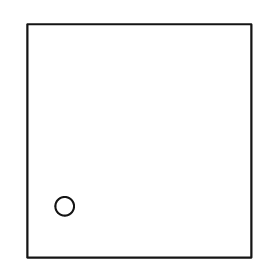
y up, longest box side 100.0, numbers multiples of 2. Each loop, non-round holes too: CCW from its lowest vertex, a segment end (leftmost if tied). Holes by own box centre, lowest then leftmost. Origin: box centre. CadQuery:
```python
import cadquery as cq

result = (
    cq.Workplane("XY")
    .moveTo(-48.0, -50.0)
    .lineTo(48.0, -50.0)
    .lineTo(48.0, 50.0)
    .lineTo(-48.0, 50.0)
    .close()
    .moveTo(-32.0, -28.0)
    .circle(4.0)
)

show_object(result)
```